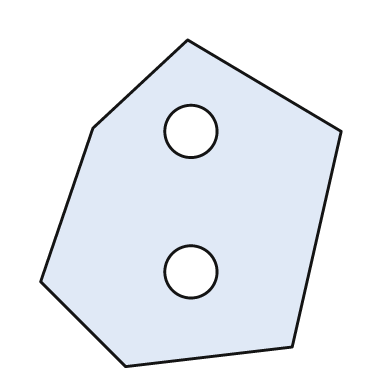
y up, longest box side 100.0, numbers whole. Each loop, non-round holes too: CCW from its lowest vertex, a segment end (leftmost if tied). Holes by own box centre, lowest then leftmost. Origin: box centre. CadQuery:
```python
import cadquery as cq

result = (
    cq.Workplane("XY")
    .moveTo(-20.0, -50.0)
    .lineTo(31.0, -44.0)
    .lineTo(46.0, 22.0)
    .lineTo(-1.0, 50.0)
    .lineTo(-30.0, 23.0)
    .lineTo(-46.0, -24.0)
    .close()
    .moveTo(0.0, -21.0)
    .circle(8.0)
    .moveTo(0.0, 22.0)
    .circle(8.0)
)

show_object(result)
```